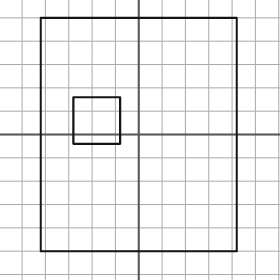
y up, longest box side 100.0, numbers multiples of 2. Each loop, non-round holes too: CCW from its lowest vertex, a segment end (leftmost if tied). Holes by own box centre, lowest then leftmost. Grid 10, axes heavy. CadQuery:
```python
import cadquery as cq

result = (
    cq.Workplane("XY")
    .moveTo(-42.0, -50.0)
    .lineTo(42.0, -50.0)
    .lineTo(42.0, 50.0)
    .lineTo(-42.0, 50.0)
    .close()
    .moveTo(-28.0, -4.0)
    .lineTo(-8.0, -4.0)
    .lineTo(-8.0, 16.0)
    .lineTo(-28.0, 16.0)
    .close()
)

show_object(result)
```